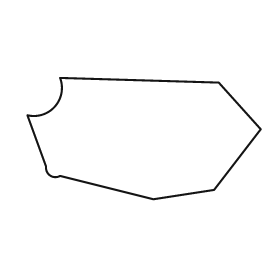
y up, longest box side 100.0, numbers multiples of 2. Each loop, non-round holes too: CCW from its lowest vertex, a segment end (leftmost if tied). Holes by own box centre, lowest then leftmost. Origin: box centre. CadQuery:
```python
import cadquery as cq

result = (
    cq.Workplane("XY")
    .moveTo(4.0, -26.0)
    .lineTo(30.0, -22.0)
    .lineTo(50.0, 4.0)
    .lineTo(32.0, 24.0)
    .lineTo(-36.0, 26.0)
    .threePointArc((-38.0, 14.0), (-50.0, 10.0))
    .lineTo(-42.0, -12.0)
    .threePointArc((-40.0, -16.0), (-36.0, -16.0))
    .close()
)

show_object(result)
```